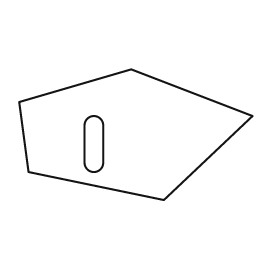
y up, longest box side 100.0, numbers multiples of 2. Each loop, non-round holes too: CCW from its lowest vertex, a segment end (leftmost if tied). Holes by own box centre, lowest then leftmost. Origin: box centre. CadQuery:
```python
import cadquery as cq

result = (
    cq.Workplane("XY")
    .moveTo(12.0, -28.0)
    .lineTo(50.0, 8.0)
    .lineTo(-2.0, 28.0)
    .lineTo(-50.0, 14.0)
    .lineTo(-46.0, -16.0)
    .close()
    .moveTo(-22.0, -12.0)
    .threePointArc((-18.0, -16.0), (-14.0, -12.0))
    .lineTo(-14.0, 4.0)
    .threePointArc((-18.0, 8.0), (-22.0, 4.0))
    .close()
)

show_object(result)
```